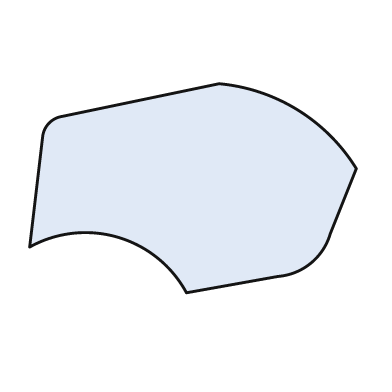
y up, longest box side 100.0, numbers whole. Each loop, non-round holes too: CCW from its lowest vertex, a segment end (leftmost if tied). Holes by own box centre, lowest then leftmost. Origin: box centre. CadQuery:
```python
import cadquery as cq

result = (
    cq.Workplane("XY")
    .moveTo(-2.0, -32.0)
    .lineTo(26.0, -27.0)
    .threePointArc((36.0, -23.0), (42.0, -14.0))
    .lineTo(50.0, 6.0)
    .threePointArc((32.0, 24.0), (8.0, 32.0))
    .lineTo(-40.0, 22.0)
    .threePointArc((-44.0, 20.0), (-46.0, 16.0))
    .lineTo(-50.0, -18.0)
    .threePointArc((-23.0, -15.0), (-2.0, -32.0))
    .close()
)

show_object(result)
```